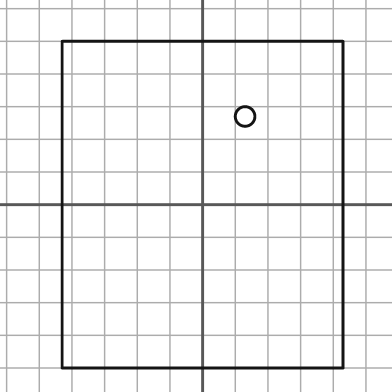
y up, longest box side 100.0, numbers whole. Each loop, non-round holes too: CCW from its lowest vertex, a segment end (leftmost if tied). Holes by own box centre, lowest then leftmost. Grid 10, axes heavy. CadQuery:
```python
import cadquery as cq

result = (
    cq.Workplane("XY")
    .moveTo(-43.0, -50.0)
    .lineTo(43.0, -50.0)
    .lineTo(43.0, 50.0)
    .lineTo(-43.0, 50.0)
    .close()
    .moveTo(13.0, 27.0)
    .circle(3.0)
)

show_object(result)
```